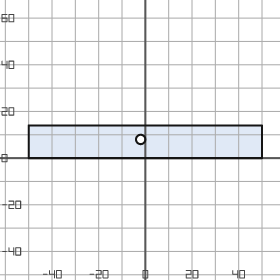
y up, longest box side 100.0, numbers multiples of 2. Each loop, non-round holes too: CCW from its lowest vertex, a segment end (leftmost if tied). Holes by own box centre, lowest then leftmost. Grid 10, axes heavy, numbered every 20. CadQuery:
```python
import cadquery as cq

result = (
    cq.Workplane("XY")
    .moveTo(-50.0, 0.0)
    .lineTo(50.0, 0.0)
    .lineTo(50.0, 14.0)
    .lineTo(-50.0, 14.0)
    .close()
    .moveTo(-2.0, 8.0)
    .circle(2.0)
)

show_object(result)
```